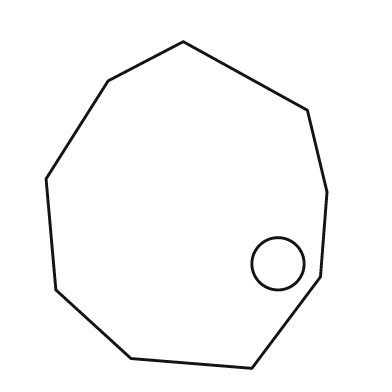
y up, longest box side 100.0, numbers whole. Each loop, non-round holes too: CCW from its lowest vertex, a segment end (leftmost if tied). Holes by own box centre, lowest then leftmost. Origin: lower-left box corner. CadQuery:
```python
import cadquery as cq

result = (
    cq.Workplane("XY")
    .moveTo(63.0, 0.0)
    .lineTo(84.0, 28.0)
    .lineTo(86.0, 54.0)
    .lineTo(80.0, 79.0)
    .lineTo(42.0, 100.0)
    .lineTo(19.0, 88.0)
    .lineTo(0.0, 58.0)
    .lineTo(3.0, 24.0)
    .lineTo(26.0, 3.0)
    .close()
    .moveTo(71.0, 32.0)
    .circle(8.0)
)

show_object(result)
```